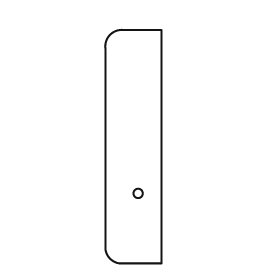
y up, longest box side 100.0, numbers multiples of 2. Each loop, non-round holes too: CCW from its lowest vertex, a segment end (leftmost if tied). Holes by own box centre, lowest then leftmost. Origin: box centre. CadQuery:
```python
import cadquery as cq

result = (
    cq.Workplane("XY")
    .moveTo(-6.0, -50.0)
    .lineTo(12.0, -50.0)
    .lineTo(12.0, 50.0)
    .lineTo(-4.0, 50.0)
    .threePointArc((-10.0, 48.0), (-12.0, 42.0))
    .lineTo(-12.0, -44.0)
    .threePointArc((-10.0, -48.0), (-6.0, -50.0))
    .close()
    .moveTo(2.0, -20.0)
    .circle(2.0)
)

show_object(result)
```